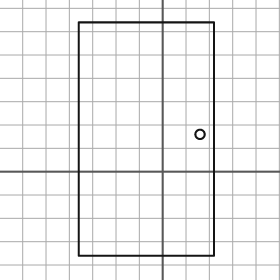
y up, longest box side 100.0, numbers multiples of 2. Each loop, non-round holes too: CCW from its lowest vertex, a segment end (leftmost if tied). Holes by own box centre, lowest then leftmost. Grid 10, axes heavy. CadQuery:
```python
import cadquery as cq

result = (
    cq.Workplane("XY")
    .moveTo(-36.0, -36.0)
    .lineTo(22.0, -36.0)
    .lineTo(22.0, 64.0)
    .lineTo(-36.0, 64.0)
    .close()
    .moveTo(16.0, 16.0)
    .circle(2.0)
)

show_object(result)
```